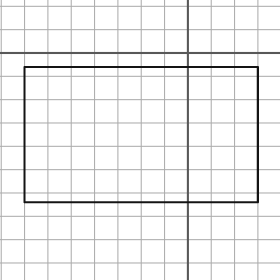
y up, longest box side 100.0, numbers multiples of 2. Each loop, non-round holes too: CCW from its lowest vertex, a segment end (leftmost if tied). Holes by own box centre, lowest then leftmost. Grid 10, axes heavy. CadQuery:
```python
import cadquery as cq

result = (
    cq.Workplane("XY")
    .moveTo(-70.0, -64.0)
    .lineTo(30.0, -64.0)
    .lineTo(30.0, -6.0)
    .lineTo(-70.0, -6.0)
    .close()
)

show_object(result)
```